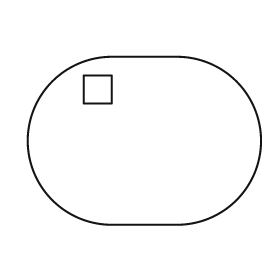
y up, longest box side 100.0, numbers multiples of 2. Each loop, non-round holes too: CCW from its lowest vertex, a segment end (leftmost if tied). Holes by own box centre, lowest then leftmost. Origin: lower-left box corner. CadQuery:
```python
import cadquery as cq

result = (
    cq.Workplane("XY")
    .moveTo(36.0, 0.0)
    .lineTo(64.0, 0.0)
    .threePointArc((100.0, 36.0), (64.0, 72.0))
    .lineTo(36.0, 72.0)
    .threePointArc((0.0, 36.0), (36.0, 0.0))
    .close()
    .moveTo(24.0, 52.0)
    .lineTo(36.0, 52.0)
    .lineTo(36.0, 64.0)
    .lineTo(24.0, 64.0)
    .close()
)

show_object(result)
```